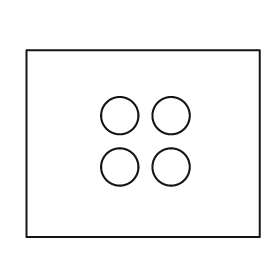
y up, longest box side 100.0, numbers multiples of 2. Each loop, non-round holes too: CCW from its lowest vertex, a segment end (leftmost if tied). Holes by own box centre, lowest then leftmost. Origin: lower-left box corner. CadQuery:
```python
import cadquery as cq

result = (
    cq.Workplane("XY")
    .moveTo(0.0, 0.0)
    .lineTo(100.0, 0.0)
    .lineTo(100.0, 80.0)
    .lineTo(0.0, 80.0)
    .close()
    .moveTo(40.0, 30.0)
    .circle(8.0)
    .moveTo(62.0, 30.0)
    .circle(8.0)
    .moveTo(40.0, 52.0)
    .circle(8.0)
    .moveTo(62.0, 52.0)
    .circle(8.0)
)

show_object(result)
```